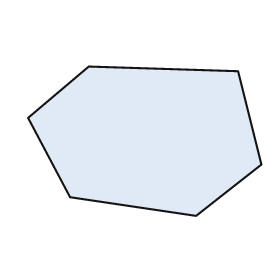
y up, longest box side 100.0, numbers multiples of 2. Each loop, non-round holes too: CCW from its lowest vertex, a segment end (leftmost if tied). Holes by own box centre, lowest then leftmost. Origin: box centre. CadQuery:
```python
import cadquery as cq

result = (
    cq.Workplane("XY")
    .moveTo(22.0, -32.0)
    .lineTo(50.0, -10.0)
    .lineTo(40.0, 30.0)
    .lineTo(-24.0, 32.0)
    .lineTo(-50.0, 10.0)
    .lineTo(-32.0, -24.0)
    .close()
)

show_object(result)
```